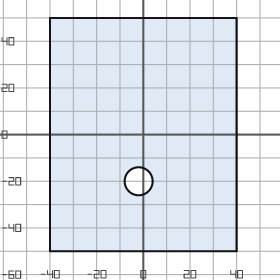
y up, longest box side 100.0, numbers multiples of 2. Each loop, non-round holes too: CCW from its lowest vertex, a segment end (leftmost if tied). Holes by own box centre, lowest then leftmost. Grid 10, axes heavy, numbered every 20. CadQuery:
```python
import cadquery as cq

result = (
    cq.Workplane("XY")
    .moveTo(-40.0, -50.0)
    .lineTo(40.0, -50.0)
    .lineTo(40.0, 50.0)
    .lineTo(-40.0, 50.0)
    .close()
    .moveTo(-2.0, -20.0)
    .circle(6.0)
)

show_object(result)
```